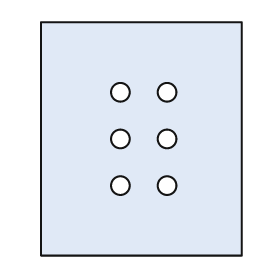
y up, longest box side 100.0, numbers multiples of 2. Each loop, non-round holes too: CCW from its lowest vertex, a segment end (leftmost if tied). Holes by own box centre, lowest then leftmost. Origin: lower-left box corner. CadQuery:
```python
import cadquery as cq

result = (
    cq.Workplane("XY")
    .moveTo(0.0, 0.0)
    .lineTo(86.0, 0.0)
    .lineTo(86.0, 100.0)
    .lineTo(0.0, 100.0)
    .close()
    .moveTo(34.0, 30.0)
    .circle(4.0)
    .moveTo(54.0, 30.0)
    .circle(4.0)
    .moveTo(34.0, 50.0)
    .circle(4.0)
    .moveTo(54.0, 50.0)
    .circle(4.0)
    .moveTo(34.0, 70.0)
    .circle(4.0)
    .moveTo(54.0, 70.0)
    .circle(4.0)
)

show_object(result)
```